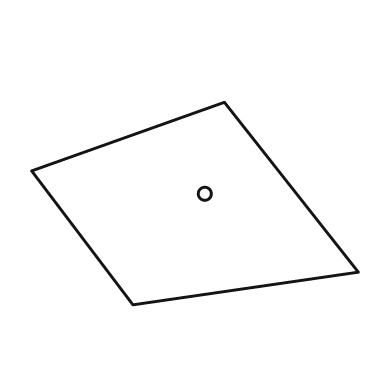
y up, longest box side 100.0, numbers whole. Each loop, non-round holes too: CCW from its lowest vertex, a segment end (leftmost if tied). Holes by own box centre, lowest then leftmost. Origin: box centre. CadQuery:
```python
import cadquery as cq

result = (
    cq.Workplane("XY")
    .moveTo(-19.0, -31.0)
    .lineTo(50.0, -21.0)
    .lineTo(9.0, 31.0)
    .lineTo(-50.0, 10.0)
    .close()
    .moveTo(3.0, 3.0)
    .circle(2.0)
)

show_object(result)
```